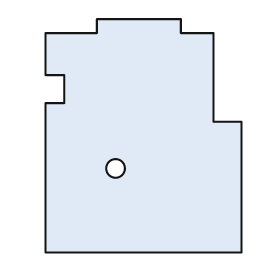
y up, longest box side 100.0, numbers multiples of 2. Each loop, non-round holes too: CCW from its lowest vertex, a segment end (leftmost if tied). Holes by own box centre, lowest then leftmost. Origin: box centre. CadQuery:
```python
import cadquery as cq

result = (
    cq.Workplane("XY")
    .moveTo(-42.0, -50.0)
    .lineTo(42.0, -50.0)
    .lineTo(42.0, 6.0)
    .lineTo(30.0, 6.0)
    .lineTo(30.0, 44.0)
    .lineTo(16.0, 44.0)
    .lineTo(16.0, 50.0)
    .lineTo(-20.0, 50.0)
    .lineTo(-20.0, 44.0)
    .lineTo(-42.0, 44.0)
    .lineTo(-42.0, 26.0)
    .lineTo(-34.0, 26.0)
    .lineTo(-34.0, 14.0)
    .lineTo(-42.0, 14.0)
    .close()
    .moveTo(-12.0, -14.0)
    .circle(4.0)
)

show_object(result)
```